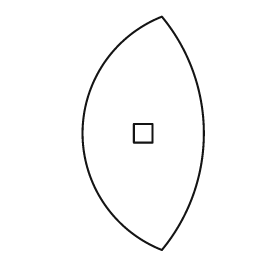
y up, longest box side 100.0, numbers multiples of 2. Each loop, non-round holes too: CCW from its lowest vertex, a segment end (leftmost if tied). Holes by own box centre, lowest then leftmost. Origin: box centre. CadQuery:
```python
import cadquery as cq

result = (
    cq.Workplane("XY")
    .moveTo(8.0, -50.0)
    .threePointArc((26.0, 0.0), (8.0, 50.0))
    .threePointArc((-26.0, 0.0), (8.0, -50.0))
    .close()
    .moveTo(-4.0, -4.0)
    .lineTo(4.0, -4.0)
    .lineTo(4.0, 4.0)
    .lineTo(-4.0, 4.0)
    .close()
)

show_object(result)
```